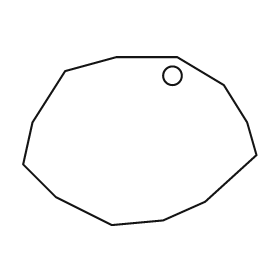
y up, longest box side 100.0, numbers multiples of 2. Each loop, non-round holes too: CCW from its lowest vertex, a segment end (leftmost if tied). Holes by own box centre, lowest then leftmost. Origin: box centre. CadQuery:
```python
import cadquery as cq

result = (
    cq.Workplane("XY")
    .moveTo(-12.0, -36.0)
    .lineTo(10.0, -34.0)
    .lineTo(28.0, -26.0)
    .lineTo(50.0, -6.0)
    .lineTo(46.0, 8.0)
    .lineTo(36.0, 24.0)
    .lineTo(16.0, 36.0)
    .lineTo(-10.0, 36.0)
    .lineTo(-32.0, 30.0)
    .lineTo(-46.0, 8.0)
    .lineTo(-50.0, -10.0)
    .lineTo(-36.0, -24.0)
    .close()
    .moveTo(14.0, 28.0)
    .circle(4.0)
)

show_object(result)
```